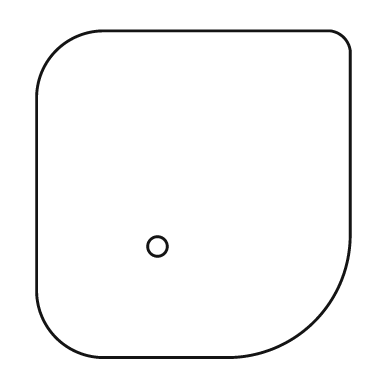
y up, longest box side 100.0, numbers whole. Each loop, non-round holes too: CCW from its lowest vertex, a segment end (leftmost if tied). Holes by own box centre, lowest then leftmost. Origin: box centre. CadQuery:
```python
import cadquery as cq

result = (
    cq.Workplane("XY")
    .moveTo(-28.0, -50.0)
    .lineTo(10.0, -50.0)
    .threePointArc((37.0, -39.0), (48.0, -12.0))
    .lineTo(48.0, 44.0)
    .threePointArc((46.0, 48.0), (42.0, 50.0))
    .lineTo(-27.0, 50.0)
    .threePointArc((-42.0, 44.0), (-48.0, 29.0))
    .lineTo(-48.0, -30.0)
    .threePointArc((-42.0, -44.0), (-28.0, -50.0))
    .close()
    .moveTo(-11.0, -16.0)
    .circle(3.0)
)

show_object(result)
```